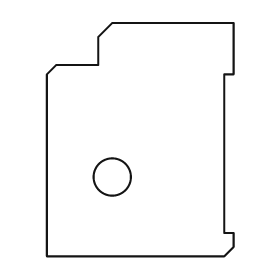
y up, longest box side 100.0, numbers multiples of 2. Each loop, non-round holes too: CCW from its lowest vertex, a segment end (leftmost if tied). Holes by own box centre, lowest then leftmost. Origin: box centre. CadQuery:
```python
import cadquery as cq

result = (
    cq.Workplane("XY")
    .moveTo(-40.0, -50.0)
    .lineTo(36.0, -50.0)
    .lineTo(40.0, -46.0)
    .lineTo(40.0, -40.0)
    .lineTo(36.0, -40.0)
    .lineTo(36.0, 28.0)
    .lineTo(40.0, 28.0)
    .lineTo(40.0, 50.0)
    .lineTo(-12.0, 50.0)
    .lineTo(-18.0, 44.0)
    .lineTo(-18.0, 32.0)
    .lineTo(-36.0, 32.0)
    .lineTo(-40.0, 28.0)
    .close()
    .moveTo(-12.0, -16.0)
    .circle(8.0)
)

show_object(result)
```